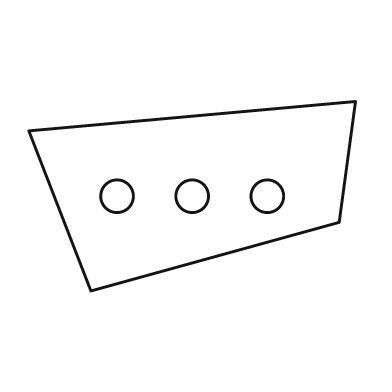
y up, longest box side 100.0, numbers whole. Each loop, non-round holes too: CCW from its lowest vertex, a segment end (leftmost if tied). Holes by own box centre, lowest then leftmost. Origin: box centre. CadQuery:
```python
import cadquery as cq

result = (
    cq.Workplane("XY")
    .moveTo(-31.0, -29.0)
    .lineTo(45.0, -8.0)
    .lineTo(50.0, 29.0)
    .lineTo(-50.0, 20.0)
    .close()
    .moveTo(-23.0, 0.0)
    .circle(5.0)
    .moveTo(0.0, 0.0)
    .circle(5.0)
    .moveTo(23.0, 0.0)
    .circle(5.0)
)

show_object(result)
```